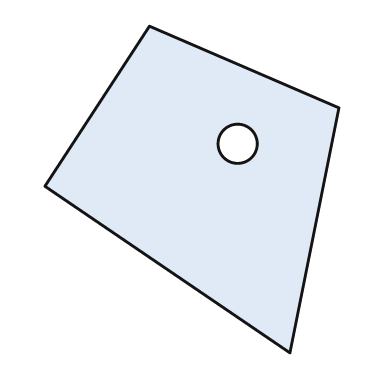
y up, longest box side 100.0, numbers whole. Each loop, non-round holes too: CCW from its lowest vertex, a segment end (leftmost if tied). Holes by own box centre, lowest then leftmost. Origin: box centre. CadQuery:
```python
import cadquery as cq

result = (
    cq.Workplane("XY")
    .moveTo(30.0, -50.0)
    .lineTo(45.0, 25.0)
    .lineTo(-13.0, 50.0)
    .lineTo(-45.0, 1.0)
    .close()
    .moveTo(14.0, 14.0)
    .circle(6.0)
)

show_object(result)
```